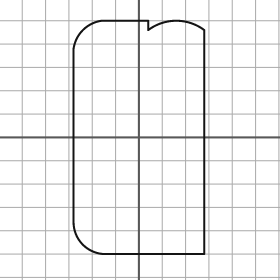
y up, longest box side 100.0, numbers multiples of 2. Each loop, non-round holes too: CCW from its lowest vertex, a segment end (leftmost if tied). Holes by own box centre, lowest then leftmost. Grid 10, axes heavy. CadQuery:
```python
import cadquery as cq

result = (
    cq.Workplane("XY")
    .moveTo(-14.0, -50.0)
    .lineTo(28.0, -50.0)
    .lineTo(28.0, 46.0)
    .threePointArc((16.0, 50.0), (4.0, 46.0))
    .lineTo(4.0, 50.0)
    .lineTo(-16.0, 50.0)
    .threePointArc((-24.0, 46.0), (-28.0, 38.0))
    .lineTo(-28.0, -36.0)
    .threePointArc((-24.0, -46.0), (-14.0, -50.0))
    .close()
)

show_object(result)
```